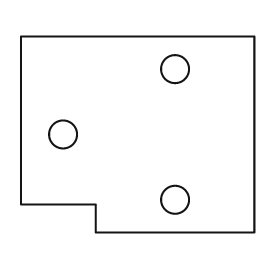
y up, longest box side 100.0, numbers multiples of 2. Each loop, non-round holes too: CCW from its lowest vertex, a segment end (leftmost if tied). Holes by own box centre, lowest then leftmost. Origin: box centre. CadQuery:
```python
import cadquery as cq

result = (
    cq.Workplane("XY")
    .moveTo(-18.0, -42.0)
    .lineTo(50.0, -42.0)
    .lineTo(50.0, 42.0)
    .lineTo(-50.0, 42.0)
    .lineTo(-50.0, -30.0)
    .lineTo(-18.0, -30.0)
    .close()
    .moveTo(16.0, -28.0)
    .circle(6.0)
    .moveTo(-32.0, 0.0)
    .circle(6.0)
    .moveTo(16.0, 28.0)
    .circle(6.0)
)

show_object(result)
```